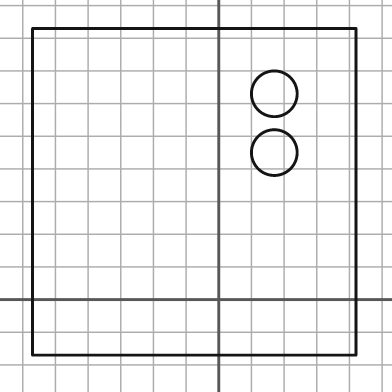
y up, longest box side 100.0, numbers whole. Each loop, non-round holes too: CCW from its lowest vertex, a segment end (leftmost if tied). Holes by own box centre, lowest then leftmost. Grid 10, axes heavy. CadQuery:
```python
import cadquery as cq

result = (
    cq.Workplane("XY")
    .moveTo(-57.0, -17.0)
    .lineTo(42.0, -17.0)
    .lineTo(42.0, 83.0)
    .lineTo(-57.0, 83.0)
    .close()
    .moveTo(17.0, 45.0)
    .circle(7.0)
    .moveTo(17.0, 63.0)
    .circle(7.0)
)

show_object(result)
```